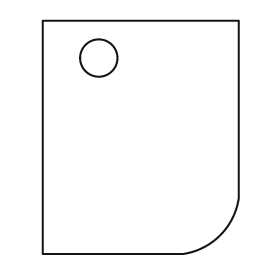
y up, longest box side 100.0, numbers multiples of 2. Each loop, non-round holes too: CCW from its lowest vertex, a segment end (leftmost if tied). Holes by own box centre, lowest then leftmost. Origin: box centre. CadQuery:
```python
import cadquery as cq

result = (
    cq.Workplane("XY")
    .moveTo(-42.0, -50.0)
    .lineTo(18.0, -50.0)
    .threePointArc((34.0, -42.0), (42.0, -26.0))
    .lineTo(42.0, 50.0)
    .lineTo(-42.0, 50.0)
    .close()
    .moveTo(-18.0, 34.0)
    .circle(8.0)
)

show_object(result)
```